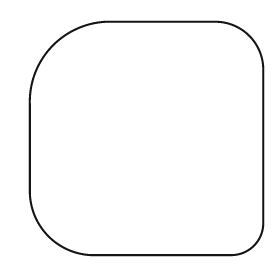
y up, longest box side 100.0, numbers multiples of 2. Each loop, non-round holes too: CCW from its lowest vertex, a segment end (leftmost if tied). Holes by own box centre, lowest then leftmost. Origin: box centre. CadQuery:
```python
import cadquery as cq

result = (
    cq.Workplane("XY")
    .moveTo(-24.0, -50.0)
    .lineTo(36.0, -50.0)
    .threePointArc((46.0, -46.0), (50.0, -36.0))
    .lineTo(50.0, 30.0)
    .threePointArc((44.0, 44.0), (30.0, 50.0))
    .lineTo(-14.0, 50.0)
    .threePointArc((-40.0, 40.0), (-50.0, 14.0))
    .lineTo(-50.0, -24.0)
    .threePointArc((-42.0, -42.0), (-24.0, -50.0))
    .close()
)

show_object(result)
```